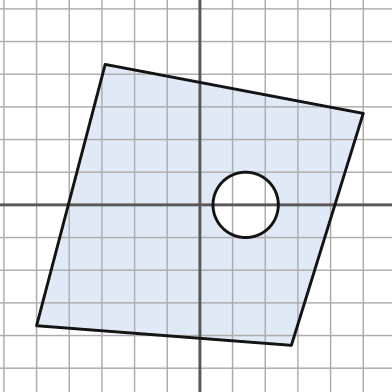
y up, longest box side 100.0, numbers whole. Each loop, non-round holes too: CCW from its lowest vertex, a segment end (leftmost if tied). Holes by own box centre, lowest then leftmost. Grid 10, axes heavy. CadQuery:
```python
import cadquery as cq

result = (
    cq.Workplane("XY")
    .moveTo(28.0, -43.0)
    .lineTo(50.0, 28.0)
    .lineTo(-29.0, 43.0)
    .lineTo(-50.0, -37.0)
    .close()
    .moveTo(14.0, 0.0)
    .circle(10.0)
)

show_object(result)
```